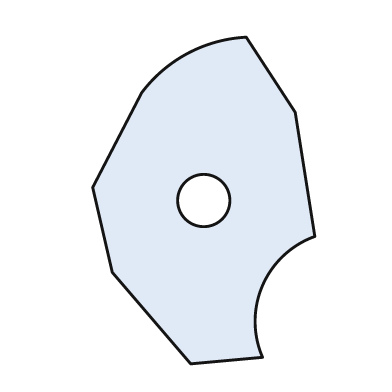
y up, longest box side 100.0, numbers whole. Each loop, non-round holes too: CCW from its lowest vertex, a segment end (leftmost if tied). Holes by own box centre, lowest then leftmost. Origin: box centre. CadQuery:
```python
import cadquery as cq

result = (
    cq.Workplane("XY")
    .moveTo(-4.0, -50.0)
    .lineTo(18.0, -48.0)
    .threePointArc((18.0, -26.0), (34.0, -11.0))
    .lineTo(28.0, 27.0)
    .lineTo(13.0, 50.0)
    .threePointArc((-5.0, 45.0), (-19.0, 33.0))
    .lineTo(-34.0, 4.0)
    .lineTo(-28.0, -22.0)
    .close()
    .moveTo(0.0, 0.0)
    .circle(8.0)
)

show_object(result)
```